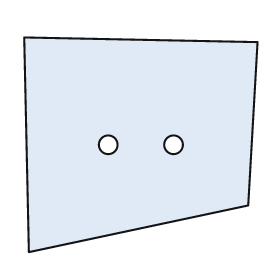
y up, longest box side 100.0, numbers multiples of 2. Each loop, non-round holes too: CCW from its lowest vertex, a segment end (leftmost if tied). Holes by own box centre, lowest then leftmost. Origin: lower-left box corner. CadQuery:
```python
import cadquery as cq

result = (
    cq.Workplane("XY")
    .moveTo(2.0, 0.0)
    .lineTo(96.0, 20.0)
    .lineTo(100.0, 90.0)
    .lineTo(0.0, 92.0)
    .close()
    .moveTo(36.0, 46.0)
    .circle(4.0)
    .moveTo(64.0, 46.0)
    .circle(4.0)
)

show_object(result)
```